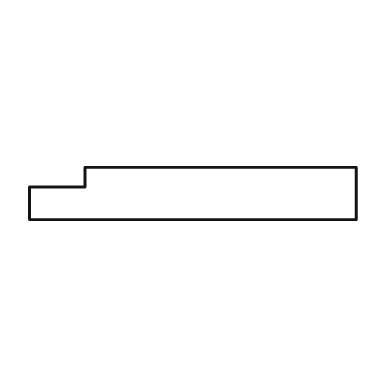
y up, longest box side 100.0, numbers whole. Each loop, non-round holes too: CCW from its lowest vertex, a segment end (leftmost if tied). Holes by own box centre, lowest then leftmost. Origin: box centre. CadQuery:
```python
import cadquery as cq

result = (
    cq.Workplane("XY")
    .moveTo(-50.0, -8.0)
    .lineTo(50.0, -8.0)
    .lineTo(50.0, 8.0)
    .lineTo(-33.0, 8.0)
    .lineTo(-33.0, 2.0)
    .lineTo(-50.0, 2.0)
    .close()
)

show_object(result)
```